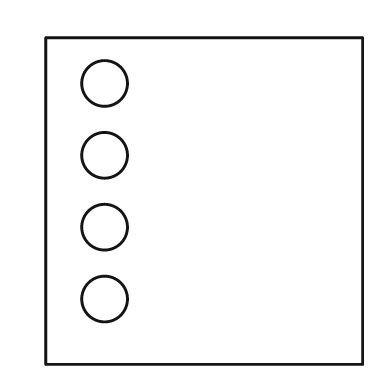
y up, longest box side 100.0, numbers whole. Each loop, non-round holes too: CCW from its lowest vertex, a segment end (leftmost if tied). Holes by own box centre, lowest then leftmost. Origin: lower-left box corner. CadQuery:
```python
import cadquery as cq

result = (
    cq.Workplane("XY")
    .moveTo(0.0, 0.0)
    .lineTo(97.0, 0.0)
    .lineTo(97.0, 100.0)
    .lineTo(0.0, 100.0)
    .close()
    .moveTo(18.0, 20.0)
    .circle(7.0)
    .moveTo(18.0, 42.0)
    .circle(7.0)
    .moveTo(18.0, 64.0)
    .circle(7.0)
    .moveTo(18.0, 86.0)
    .circle(7.0)
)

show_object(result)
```